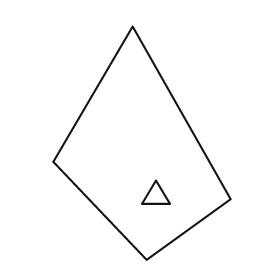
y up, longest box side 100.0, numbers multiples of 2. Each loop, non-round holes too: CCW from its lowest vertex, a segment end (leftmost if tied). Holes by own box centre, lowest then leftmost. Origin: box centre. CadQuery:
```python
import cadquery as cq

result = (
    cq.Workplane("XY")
    .moveTo(2.0, -50.0)
    .lineTo(38.0, -24.0)
    .lineTo(-4.0, 50.0)
    .lineTo(-38.0, -8.0)
    .close()
    .moveTo(0.0, -26.0)
    .lineTo(12.0, -26.0)
    .lineTo(6.0, -16.0)
    .close()
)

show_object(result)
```